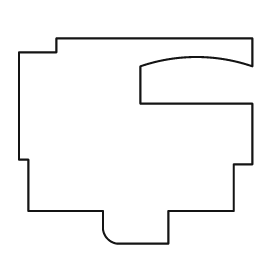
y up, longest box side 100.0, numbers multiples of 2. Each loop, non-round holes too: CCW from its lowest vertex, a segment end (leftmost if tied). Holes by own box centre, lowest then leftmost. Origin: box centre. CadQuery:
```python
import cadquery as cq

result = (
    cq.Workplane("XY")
    .moveTo(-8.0, -44.0)
    .lineTo(14.0, -44.0)
    .lineTo(14.0, -30.0)
    .lineTo(42.0, -30.0)
    .lineTo(42.0, -10.0)
    .lineTo(50.0, -10.0)
    .lineTo(50.0, 16.0)
    .lineTo(2.0, 16.0)
    .lineTo(2.0, 32.0)
    .threePointArc((26.0, 36.0), (50.0, 32.0))
    .lineTo(50.0, 44.0)
    .lineTo(-34.0, 44.0)
    .lineTo(-34.0, 38.0)
    .lineTo(-50.0, 38.0)
    .lineTo(-50.0, -8.0)
    .lineTo(-46.0, -8.0)
    .lineTo(-46.0, -30.0)
    .lineTo(-14.0, -30.0)
    .lineTo(-14.0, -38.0)
    .threePointArc((-12.0, -42.0), (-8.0, -44.0))
    .close()
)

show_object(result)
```